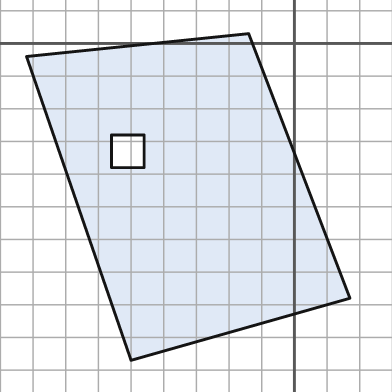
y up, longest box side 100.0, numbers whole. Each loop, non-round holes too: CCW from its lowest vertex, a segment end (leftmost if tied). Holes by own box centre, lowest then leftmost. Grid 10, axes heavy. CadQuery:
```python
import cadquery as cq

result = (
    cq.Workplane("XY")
    .moveTo(-50.0, -97.0)
    .lineTo(17.0, -78.0)
    .lineTo(-14.0, 3.0)
    .lineTo(-82.0, -4.0)
    .close()
    .moveTo(-56.0, -38.0)
    .lineTo(-46.0, -38.0)
    .lineTo(-46.0, -28.0)
    .lineTo(-56.0, -28.0)
    .close()
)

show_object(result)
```